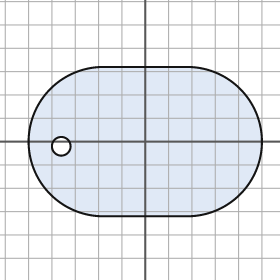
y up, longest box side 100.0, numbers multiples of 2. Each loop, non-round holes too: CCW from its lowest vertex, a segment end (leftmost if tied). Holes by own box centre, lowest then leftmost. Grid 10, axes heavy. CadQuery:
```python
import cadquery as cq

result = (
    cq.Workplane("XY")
    .moveTo(-18.0, -32.0)
    .lineTo(18.0, -32.0)
    .threePointArc((50.0, 0.0), (18.0, 32.0))
    .lineTo(-18.0, 32.0)
    .threePointArc((-50.0, 0.0), (-18.0, -32.0))
    .close()
    .moveTo(-36.0, -2.0)
    .circle(4.0)
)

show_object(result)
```